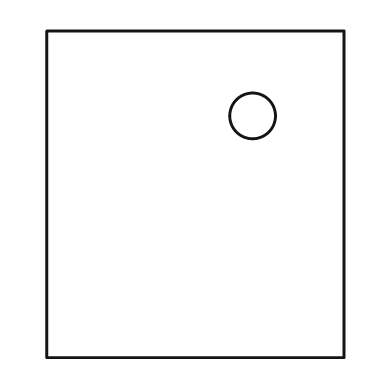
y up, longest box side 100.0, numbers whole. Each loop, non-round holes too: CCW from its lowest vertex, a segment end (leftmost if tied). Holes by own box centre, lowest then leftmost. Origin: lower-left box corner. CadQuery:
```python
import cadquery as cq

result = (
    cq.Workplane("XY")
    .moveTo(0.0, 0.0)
    .lineTo(91.0, 0.0)
    .lineTo(91.0, 100.0)
    .lineTo(0.0, 100.0)
    .close()
    .moveTo(63.0, 74.0)
    .circle(7.0)
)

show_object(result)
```